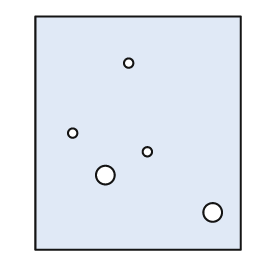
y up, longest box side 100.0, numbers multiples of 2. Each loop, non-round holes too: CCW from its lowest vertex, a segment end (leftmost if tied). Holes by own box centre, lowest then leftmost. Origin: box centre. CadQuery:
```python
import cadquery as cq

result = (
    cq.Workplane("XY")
    .moveTo(-44.0, -50.0)
    .lineTo(44.0, -50.0)
    .lineTo(44.0, 50.0)
    .lineTo(-44.0, 50.0)
    .close()
    .moveTo(32.0, -34.0)
    .circle(4.0)
    .moveTo(-14.0, -18.0)
    .circle(4.0)
    .moveTo(4.0, -8.0)
    .circle(2.0)
    .moveTo(-28.0, 0.0)
    .circle(2.0)
    .moveTo(-4.0, 30.0)
    .circle(2.0)
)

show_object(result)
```